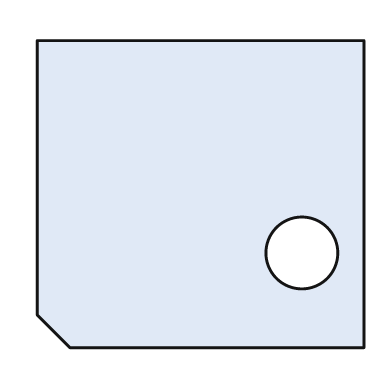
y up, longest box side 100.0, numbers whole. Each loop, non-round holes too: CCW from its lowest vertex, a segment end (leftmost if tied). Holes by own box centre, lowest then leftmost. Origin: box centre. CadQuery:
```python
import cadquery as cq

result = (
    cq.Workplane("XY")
    .moveTo(-40.0, -47.0)
    .lineTo(50.0, -47.0)
    .lineTo(50.0, 47.0)
    .lineTo(-50.0, 47.0)
    .lineTo(-50.0, -37.0)
    .close()
    .moveTo(31.0, -18.0)
    .circle(11.0)
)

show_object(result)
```